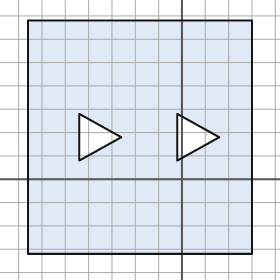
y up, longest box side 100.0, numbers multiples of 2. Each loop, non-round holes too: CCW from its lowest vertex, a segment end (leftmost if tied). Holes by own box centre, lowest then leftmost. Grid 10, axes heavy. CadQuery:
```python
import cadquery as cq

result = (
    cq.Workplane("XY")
    .moveTo(-66.0, -32.0)
    .lineTo(30.0, -32.0)
    .lineTo(30.0, 68.0)
    .lineTo(-66.0, 68.0)
    .close()
    .moveTo(-44.0, 8.0)
    .lineTo(-26.0, 18.0)
    .lineTo(-44.0, 28.0)
    .close()
    .moveTo(-2.0, 8.0)
    .lineTo(16.0, 18.0)
    .lineTo(-2.0, 28.0)
    .close()
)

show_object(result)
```